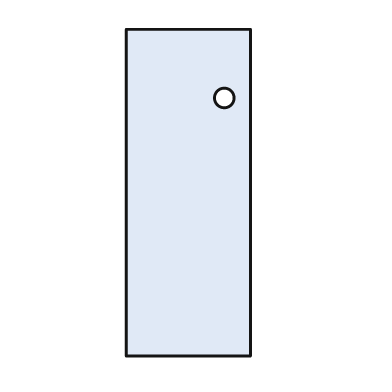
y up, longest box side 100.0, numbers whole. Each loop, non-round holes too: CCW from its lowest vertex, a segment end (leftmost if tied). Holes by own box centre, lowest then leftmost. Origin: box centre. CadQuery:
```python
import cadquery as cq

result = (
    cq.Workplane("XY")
    .moveTo(-19.0, -50.0)
    .lineTo(19.0, -50.0)
    .lineTo(19.0, 50.0)
    .lineTo(-19.0, 50.0)
    .close()
    .moveTo(11.0, 29.0)
    .circle(3.0)
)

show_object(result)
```